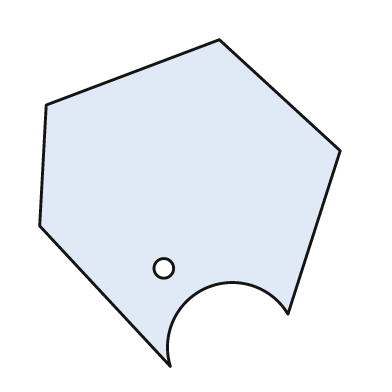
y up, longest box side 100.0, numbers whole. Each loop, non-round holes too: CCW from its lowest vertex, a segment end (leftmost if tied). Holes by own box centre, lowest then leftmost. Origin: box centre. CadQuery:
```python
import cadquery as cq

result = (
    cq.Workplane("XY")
    .moveTo(-6.0, -50.0)
    .threePointArc((5.0, -26.0), (30.0, -34.0))
    .lineTo(46.0, 16.0)
    .lineTo(9.0, 50.0)
    .lineTo(-44.0, 30.0)
    .lineTo(-46.0, -7.0)
    .close()
    .moveTo(-8.0, -20.0)
    .circle(3.0)
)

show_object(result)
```